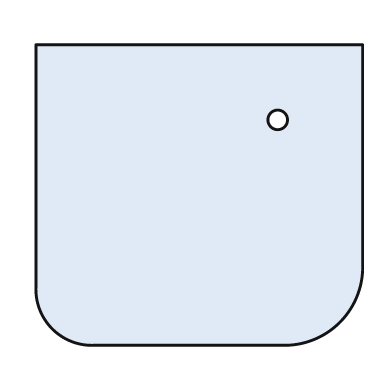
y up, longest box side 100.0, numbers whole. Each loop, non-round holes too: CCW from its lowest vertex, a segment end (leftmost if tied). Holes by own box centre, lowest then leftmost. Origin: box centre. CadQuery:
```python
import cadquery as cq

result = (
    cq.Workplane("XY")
    .moveTo(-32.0, -46.0)
    .lineTo(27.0, -46.0)
    .threePointArc((43.0, -39.0), (50.0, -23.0))
    .lineTo(50.0, 46.0)
    .lineTo(-50.0, 46.0)
    .lineTo(-50.0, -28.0)
    .threePointArc((-45.0, -41.0), (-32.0, -46.0))
    .close()
    .moveTo(24.0, 23.0)
    .circle(3.0)
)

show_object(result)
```